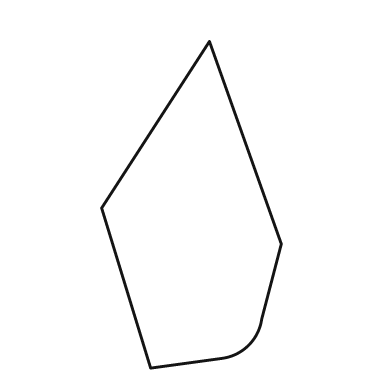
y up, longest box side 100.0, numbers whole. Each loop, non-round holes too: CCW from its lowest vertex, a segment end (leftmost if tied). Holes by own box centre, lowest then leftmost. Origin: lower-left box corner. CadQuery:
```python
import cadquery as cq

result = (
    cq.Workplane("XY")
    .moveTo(15.0, 0.0)
    .lineTo(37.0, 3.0)
    .threePointArc((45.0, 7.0), (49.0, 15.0))
    .lineTo(55.0, 38.0)
    .lineTo(33.0, 100.0)
    .lineTo(0.0, 49.0)
    .close()
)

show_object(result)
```